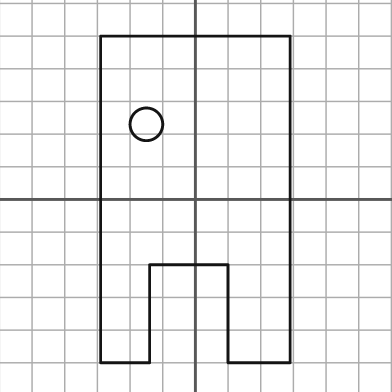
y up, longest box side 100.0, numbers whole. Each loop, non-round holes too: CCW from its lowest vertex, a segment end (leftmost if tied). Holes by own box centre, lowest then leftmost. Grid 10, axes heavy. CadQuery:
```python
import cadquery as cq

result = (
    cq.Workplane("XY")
    .moveTo(-29.0, -50.0)
    .lineTo(-14.0, -50.0)
    .lineTo(-14.0, -20.0)
    .lineTo(10.0, -20.0)
    .lineTo(10.0, -50.0)
    .lineTo(29.0, -50.0)
    .lineTo(29.0, 50.0)
    .lineTo(-29.0, 50.0)
    .close()
    .moveTo(-15.0, 23.0)
    .circle(5.0)
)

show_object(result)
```